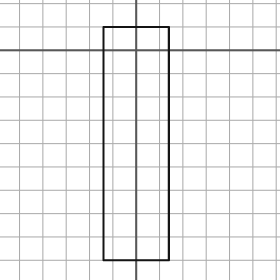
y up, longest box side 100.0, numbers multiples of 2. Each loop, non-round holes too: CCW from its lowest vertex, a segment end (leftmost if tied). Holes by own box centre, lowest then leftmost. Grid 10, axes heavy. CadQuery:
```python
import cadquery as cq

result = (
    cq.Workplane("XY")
    .moveTo(-14.0, -90.0)
    .lineTo(14.0, -90.0)
    .lineTo(14.0, 10.0)
    .lineTo(-14.0, 10.0)
    .close()
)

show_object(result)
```